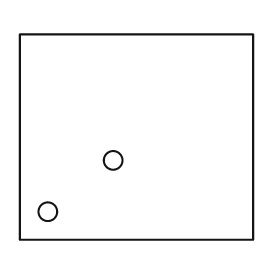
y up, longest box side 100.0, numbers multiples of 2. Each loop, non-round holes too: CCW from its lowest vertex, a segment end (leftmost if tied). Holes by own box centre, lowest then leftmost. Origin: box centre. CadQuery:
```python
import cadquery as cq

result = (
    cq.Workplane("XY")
    .moveTo(-50.0, -44.0)
    .lineTo(50.0, -44.0)
    .lineTo(50.0, 44.0)
    .lineTo(-50.0, 44.0)
    .close()
    .moveTo(-38.0, -32.0)
    .circle(4.0)
    .moveTo(-10.0, -10.0)
    .circle(4.0)
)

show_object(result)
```